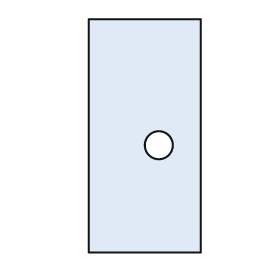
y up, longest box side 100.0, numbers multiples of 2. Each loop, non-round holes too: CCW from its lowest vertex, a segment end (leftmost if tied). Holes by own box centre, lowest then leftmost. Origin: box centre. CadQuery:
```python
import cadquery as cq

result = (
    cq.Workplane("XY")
    .moveTo(-24.0, -50.0)
    .lineTo(24.0, -50.0)
    .lineTo(24.0, 50.0)
    .lineTo(-24.0, 50.0)
    .close()
    .moveTo(6.0, -4.0)
    .circle(6.0)
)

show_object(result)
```